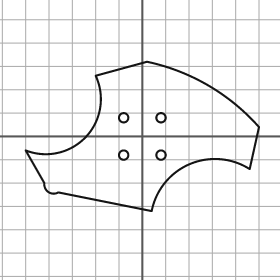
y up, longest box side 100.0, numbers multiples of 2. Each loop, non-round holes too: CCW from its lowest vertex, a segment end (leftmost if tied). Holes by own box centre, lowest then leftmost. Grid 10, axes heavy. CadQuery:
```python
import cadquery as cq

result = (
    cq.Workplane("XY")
    .moveTo(4.0, -32.0)
    .threePointArc((20.0, -12.0), (46.0, -14.0))
    .lineTo(50.0, 4.0)
    .threePointArc((28.0, 22.0), (2.0, 32.0))
    .lineTo(-20.0, 26.0)
    .threePointArc((-24.0, 0.0), (-50.0, -6.0))
    .lineTo(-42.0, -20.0)
    .threePointArc((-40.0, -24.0), (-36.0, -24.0))
    .close()
    .moveTo(-8.0, -8.0)
    .circle(2.0)
    .moveTo(8.0, -8.0)
    .circle(2.0)
    .moveTo(-8.0, 8.0)
    .circle(2.0)
    .moveTo(8.0, 8.0)
    .circle(2.0)
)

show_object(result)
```